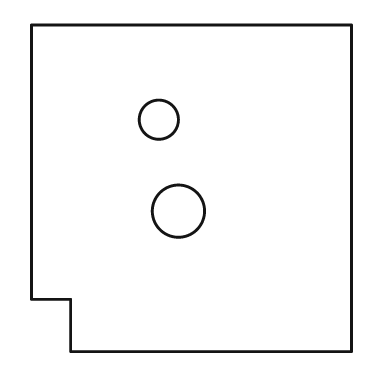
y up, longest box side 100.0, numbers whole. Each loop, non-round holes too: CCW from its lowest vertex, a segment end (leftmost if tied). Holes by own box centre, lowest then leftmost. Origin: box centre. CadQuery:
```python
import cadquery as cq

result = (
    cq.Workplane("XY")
    .moveTo(-37.0, -50.0)
    .lineTo(49.0, -50.0)
    .lineTo(49.0, 50.0)
    .lineTo(-49.0, 50.0)
    .lineTo(-49.0, -34.0)
    .lineTo(-37.0, -34.0)
    .close()
    .moveTo(-4.0, -7.0)
    .circle(8.0)
    .moveTo(-10.0, 21.0)
    .circle(6.0)
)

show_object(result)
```